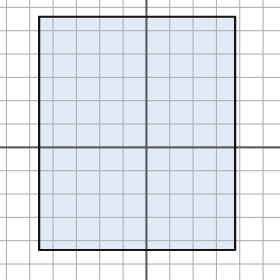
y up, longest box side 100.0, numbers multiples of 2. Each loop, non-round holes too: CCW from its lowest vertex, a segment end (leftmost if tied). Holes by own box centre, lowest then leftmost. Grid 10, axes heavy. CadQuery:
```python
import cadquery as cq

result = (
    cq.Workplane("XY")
    .moveTo(-46.0, -44.0)
    .lineTo(38.0, -44.0)
    .lineTo(38.0, 56.0)
    .lineTo(-46.0, 56.0)
    .close()
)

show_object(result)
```